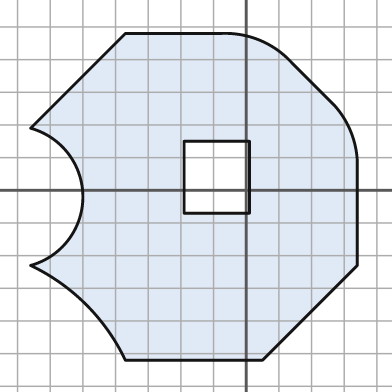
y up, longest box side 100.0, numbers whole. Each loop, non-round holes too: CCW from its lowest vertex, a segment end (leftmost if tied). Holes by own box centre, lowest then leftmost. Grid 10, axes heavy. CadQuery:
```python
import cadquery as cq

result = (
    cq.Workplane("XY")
    .moveTo(-37.0, -52.0)
    .lineTo(5.0, -52.0)
    .lineTo(34.0, -23.0)
    .lineTo(34.0, 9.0)
    .threePointArc((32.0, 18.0), (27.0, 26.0))
    .lineTo(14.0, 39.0)
    .threePointArc((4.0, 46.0), (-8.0, 48.0))
    .lineTo(-37.0, 48.0)
    .lineTo(-66.0, 19.0)
    .threePointArc((-50.0, -2.0), (-66.0, -23.0))
    .threePointArc((-49.0, -35.0), (-37.0, -52.0))
    .close()
    .moveTo(-19.0, -7.0)
    .lineTo(1.0, -7.0)
    .lineTo(1.0, 15.0)
    .lineTo(-19.0, 15.0)
    .close()
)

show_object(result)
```